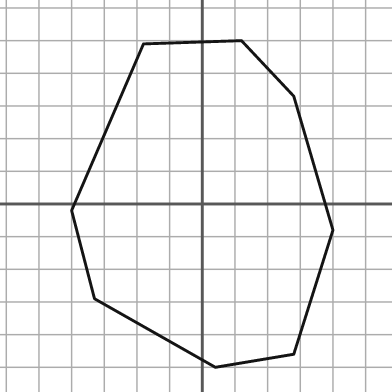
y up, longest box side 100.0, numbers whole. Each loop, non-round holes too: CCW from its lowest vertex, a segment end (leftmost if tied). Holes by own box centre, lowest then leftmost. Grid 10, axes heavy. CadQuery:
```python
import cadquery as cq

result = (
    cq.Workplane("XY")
    .moveTo(4.0, -50.0)
    .lineTo(28.0, -46.0)
    .lineTo(40.0, -8.0)
    .lineTo(28.0, 33.0)
    .lineTo(12.0, 50.0)
    .lineTo(-18.0, 49.0)
    .lineTo(-40.0, -2.0)
    .lineTo(-33.0, -29.0)
    .close()
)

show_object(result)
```